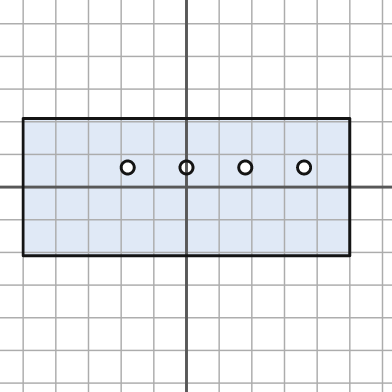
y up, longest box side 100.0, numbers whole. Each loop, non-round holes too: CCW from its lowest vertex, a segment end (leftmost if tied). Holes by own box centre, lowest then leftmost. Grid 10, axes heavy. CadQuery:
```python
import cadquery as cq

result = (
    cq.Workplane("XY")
    .moveTo(-50.0, -21.0)
    .lineTo(50.0, -21.0)
    .lineTo(50.0, 21.0)
    .lineTo(-50.0, 21.0)
    .close()
    .moveTo(-18.0, 6.0)
    .circle(2.0)
    .moveTo(0.0, 6.0)
    .circle(2.0)
    .moveTo(18.0, 6.0)
    .circle(2.0)
    .moveTo(36.0, 6.0)
    .circle(2.0)
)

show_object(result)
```